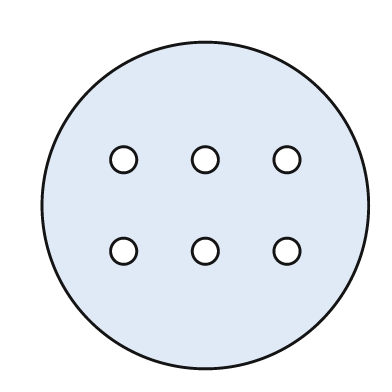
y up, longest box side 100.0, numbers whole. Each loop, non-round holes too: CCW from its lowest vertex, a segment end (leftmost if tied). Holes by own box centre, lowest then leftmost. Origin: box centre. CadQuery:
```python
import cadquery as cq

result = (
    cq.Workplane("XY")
    .moveTo(0.0, 0.0)
    .circle(50.0)
    .moveTo(-25.0, -14.0)
    .circle(4.0)
    .moveTo(0.0, -14.0)
    .circle(4.0)
    .moveTo(25.0, -14.0)
    .circle(4.0)
    .moveTo(-25.0, 14.0)
    .circle(4.0)
    .moveTo(0.0, 14.0)
    .circle(4.0)
    .moveTo(25.0, 14.0)
    .circle(4.0)
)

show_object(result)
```